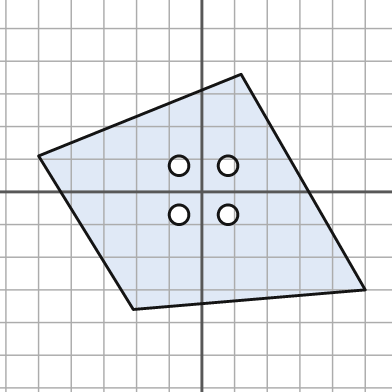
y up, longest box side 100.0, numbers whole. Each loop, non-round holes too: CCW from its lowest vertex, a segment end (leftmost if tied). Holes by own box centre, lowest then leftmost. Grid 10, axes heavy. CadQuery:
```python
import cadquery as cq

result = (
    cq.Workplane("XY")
    .moveTo(-21.0, -36.0)
    .lineTo(50.0, -30.0)
    .lineTo(12.0, 36.0)
    .lineTo(-50.0, 11.0)
    .close()
    .moveTo(-7.0, -7.0)
    .circle(3.0)
    .moveTo(8.0, -7.0)
    .circle(3.0)
    .moveTo(-7.0, 8.0)
    .circle(3.0)
    .moveTo(8.0, 8.0)
    .circle(3.0)
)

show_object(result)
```